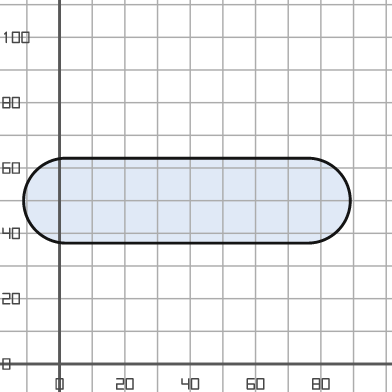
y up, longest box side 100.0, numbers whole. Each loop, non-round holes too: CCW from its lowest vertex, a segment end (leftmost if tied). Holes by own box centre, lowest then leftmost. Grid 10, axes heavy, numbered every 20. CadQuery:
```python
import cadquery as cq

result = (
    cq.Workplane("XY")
    .moveTo(2.0, 37.0)
    .lineTo(76.0, 37.0)
    .threePointArc((89.0, 50.0), (76.0, 63.0))
    .lineTo(2.0, 63.0)
    .threePointArc((-11.0, 50.0), (2.0, 37.0))
    .close()
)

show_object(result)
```